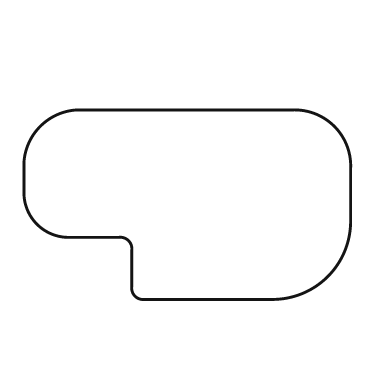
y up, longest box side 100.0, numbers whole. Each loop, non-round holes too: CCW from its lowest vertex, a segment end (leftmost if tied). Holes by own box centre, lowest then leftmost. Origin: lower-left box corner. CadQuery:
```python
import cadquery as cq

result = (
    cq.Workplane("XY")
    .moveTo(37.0, 0.0)
    .lineTo(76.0, 0.0)
    .threePointArc((93.0, 7.0), (100.0, 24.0))
    .lineTo(100.0, 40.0)
    .threePointArc((95.0, 53.0), (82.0, 58.0))
    .lineTo(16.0, 58.0)
    .threePointArc((5.0, 53.0), (0.0, 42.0))
    .lineTo(0.0, 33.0)
    .threePointArc((4.0, 23.0), (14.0, 19.0))
    .lineTo(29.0, 19.0)
    .threePointArc((32.0, 18.0), (33.0, 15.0))
    .lineTo(33.0, 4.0)
    .threePointArc((34.0, 1.0), (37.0, 0.0))
    .close()
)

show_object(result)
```